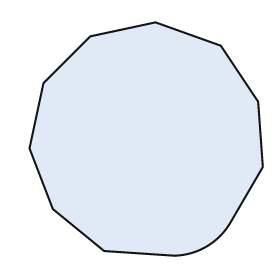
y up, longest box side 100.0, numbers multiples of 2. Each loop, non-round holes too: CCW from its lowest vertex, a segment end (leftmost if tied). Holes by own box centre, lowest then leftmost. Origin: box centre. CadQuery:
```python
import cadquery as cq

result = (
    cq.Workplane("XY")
    .moveTo(12.0, -50.0)
    .threePointArc((26.0, -46.0), (36.0, -36.0))
    .lineTo(50.0, -12.0)
    .lineTo(48.0, 16.0)
    .lineTo(32.0, 40.0)
    .lineTo(4.0, 50.0)
    .lineTo(-24.0, 44.0)
    .lineTo(-44.0, 24.0)
    .lineTo(-50.0, -4.0)
    .lineTo(-40.0, -30.0)
    .lineTo(-18.0, -48.0)
    .close()
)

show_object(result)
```